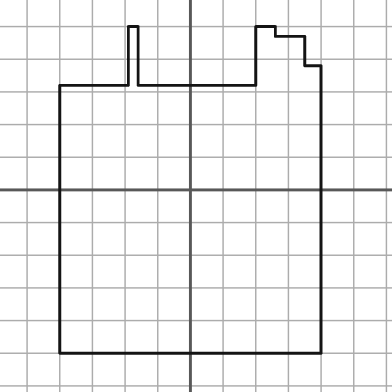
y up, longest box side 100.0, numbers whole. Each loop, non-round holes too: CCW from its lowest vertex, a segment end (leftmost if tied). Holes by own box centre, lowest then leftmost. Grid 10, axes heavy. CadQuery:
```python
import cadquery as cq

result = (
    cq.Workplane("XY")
    .moveTo(-40.0, -50.0)
    .lineTo(40.0, -50.0)
    .lineTo(40.0, 38.0)
    .lineTo(35.0, 38.0)
    .lineTo(35.0, 47.0)
    .lineTo(26.0, 47.0)
    .lineTo(26.0, 50.0)
    .lineTo(20.0, 50.0)
    .lineTo(20.0, 32.0)
    .lineTo(-16.0, 32.0)
    .lineTo(-16.0, 50.0)
    .lineTo(-19.0, 50.0)
    .lineTo(-19.0, 32.0)
    .lineTo(-40.0, 32.0)
    .close()
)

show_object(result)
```